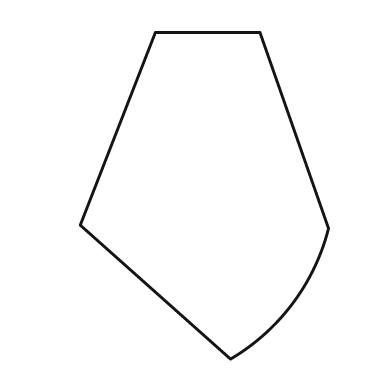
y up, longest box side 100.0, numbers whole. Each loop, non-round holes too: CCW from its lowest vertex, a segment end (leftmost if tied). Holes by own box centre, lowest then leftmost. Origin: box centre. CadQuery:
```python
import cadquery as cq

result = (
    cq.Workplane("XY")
    .moveTo(8.0, -50.0)
    .threePointArc((27.0, -33.0), (38.0, -10.0))
    .lineTo(17.0, 50.0)
    .lineTo(-15.0, 50.0)
    .lineTo(-38.0, -9.0)
    .close()
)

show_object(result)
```